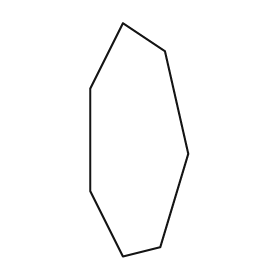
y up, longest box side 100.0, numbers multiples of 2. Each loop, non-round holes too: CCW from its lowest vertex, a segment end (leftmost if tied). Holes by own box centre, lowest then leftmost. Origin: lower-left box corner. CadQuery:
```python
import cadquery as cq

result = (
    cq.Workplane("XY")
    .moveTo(14.0, 0.0)
    .lineTo(30.0, 4.0)
    .lineTo(42.0, 44.0)
    .lineTo(32.0, 88.0)
    .lineTo(14.0, 100.0)
    .lineTo(0.0, 72.0)
    .lineTo(0.0, 28.0)
    .close()
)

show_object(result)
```